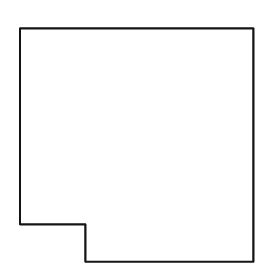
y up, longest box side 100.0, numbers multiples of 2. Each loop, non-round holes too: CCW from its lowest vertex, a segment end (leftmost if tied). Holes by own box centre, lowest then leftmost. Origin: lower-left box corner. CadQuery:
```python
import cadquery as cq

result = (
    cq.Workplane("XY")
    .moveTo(28.0, 0.0)
    .lineTo(100.0, 0.0)
    .lineTo(100.0, 100.0)
    .lineTo(0.0, 100.0)
    .lineTo(0.0, 16.0)
    .lineTo(28.0, 16.0)
    .close()
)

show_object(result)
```